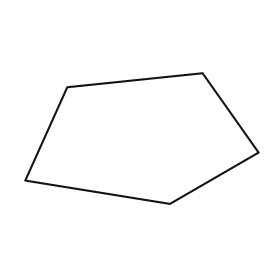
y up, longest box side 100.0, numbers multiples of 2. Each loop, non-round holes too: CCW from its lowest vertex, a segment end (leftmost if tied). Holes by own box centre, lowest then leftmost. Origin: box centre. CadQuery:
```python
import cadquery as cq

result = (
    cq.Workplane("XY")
    .moveTo(12.0, -28.0)
    .lineTo(50.0, -6.0)
    .lineTo(26.0, 28.0)
    .lineTo(-32.0, 22.0)
    .lineTo(-50.0, -18.0)
    .close()
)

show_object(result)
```